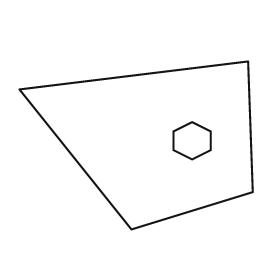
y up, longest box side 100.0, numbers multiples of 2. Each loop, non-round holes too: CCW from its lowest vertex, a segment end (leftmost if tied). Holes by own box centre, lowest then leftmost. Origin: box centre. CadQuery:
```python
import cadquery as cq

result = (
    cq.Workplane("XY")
    .moveTo(-2.0, -36.0)
    .lineTo(50.0, -20.0)
    .lineTo(48.0, 36.0)
    .lineTo(-50.0, 24.0)
    .close()
    .moveTo(24.0, -6.0)
    .lineTo(32.0, -2.0)
    .lineTo(32.0, 6.0)
    .lineTo(24.0, 10.0)
    .lineTo(16.0, 6.0)
    .lineTo(16.0, -2.0)
    .close()
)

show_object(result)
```